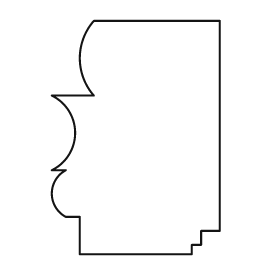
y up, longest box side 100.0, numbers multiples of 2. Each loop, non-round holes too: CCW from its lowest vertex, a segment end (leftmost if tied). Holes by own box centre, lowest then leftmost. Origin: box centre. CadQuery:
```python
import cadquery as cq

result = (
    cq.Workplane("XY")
    .moveTo(-24.0, -50.0)
    .lineTo(24.0, -50.0)
    .lineTo(24.0, -46.0)
    .lineTo(28.0, -46.0)
    .lineTo(28.0, -40.0)
    .lineTo(36.0, -40.0)
    .lineTo(36.0, 50.0)
    .lineTo(-18.0, 50.0)
    .threePointArc((-24.0, 34.0), (-18.0, 18.0))
    .lineTo(-36.0, 18.0)
    .threePointArc((-26.0, 2.0), (-36.0, -14.0))
    .lineTo(-30.0, -14.0)
    .threePointArc((-36.0, -24.0), (-30.0, -34.0))
    .lineTo(-24.0, -34.0)
    .close()
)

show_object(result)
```